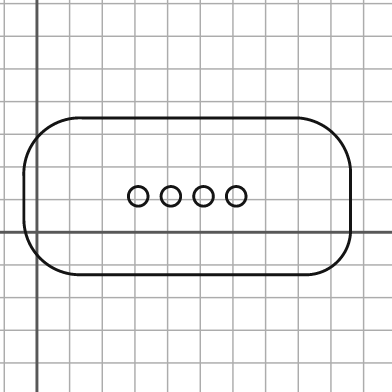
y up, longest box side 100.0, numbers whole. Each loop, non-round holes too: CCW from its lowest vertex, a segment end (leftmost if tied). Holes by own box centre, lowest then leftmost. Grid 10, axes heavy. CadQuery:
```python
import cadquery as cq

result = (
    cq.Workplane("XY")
    .moveTo(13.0, -13.0)
    .lineTo(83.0, -13.0)
    .threePointArc((92.0, -9.0), (96.0, 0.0))
    .lineTo(96.0, 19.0)
    .threePointArc((91.0, 30.0), (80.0, 35.0))
    .lineTo(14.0, 35.0)
    .threePointArc((1.0, 30.0), (-4.0, 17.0))
    .lineTo(-4.0, 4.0)
    .threePointArc((1.0, -8.0), (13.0, -13.0))
    .close()
    .moveTo(31.0, 11.0)
    .circle(3.0)
    .moveTo(41.0, 11.0)
    .circle(3.0)
    .moveTo(51.0, 11.0)
    .circle(3.0)
    .moveTo(61.0, 11.0)
    .circle(3.0)
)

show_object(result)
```